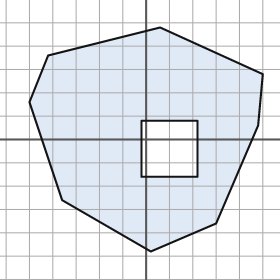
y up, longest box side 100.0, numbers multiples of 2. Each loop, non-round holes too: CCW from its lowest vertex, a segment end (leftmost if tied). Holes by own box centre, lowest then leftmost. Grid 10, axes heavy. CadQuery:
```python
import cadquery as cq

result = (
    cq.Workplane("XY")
    .moveTo(2.0, -48.0)
    .lineTo(30.0, -36.0)
    .lineTo(48.0, 6.0)
    .lineTo(50.0, 28.0)
    .lineTo(6.0, 48.0)
    .lineTo(-42.0, 36.0)
    .lineTo(-50.0, 16.0)
    .lineTo(-36.0, -26.0)
    .close()
    .moveTo(-2.0, -16.0)
    .lineTo(22.0, -16.0)
    .lineTo(22.0, 8.0)
    .lineTo(-2.0, 8.0)
    .close()
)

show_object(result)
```